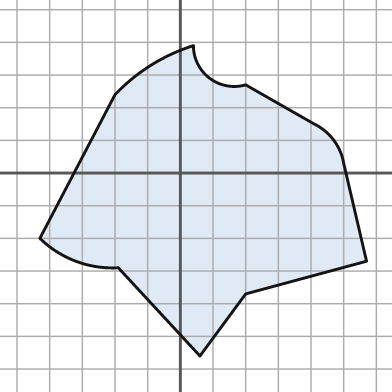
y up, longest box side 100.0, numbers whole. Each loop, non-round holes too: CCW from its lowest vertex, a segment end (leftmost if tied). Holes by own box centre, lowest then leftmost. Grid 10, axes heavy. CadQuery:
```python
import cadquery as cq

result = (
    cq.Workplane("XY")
    .moveTo(6.0, -56.0)
    .lineTo(20.0, -37.0)
    .lineTo(57.0, -27.0)
    .lineTo(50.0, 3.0)
    .threePointArc((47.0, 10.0), (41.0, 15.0))
    .lineTo(20.0, 27.0)
    .threePointArc((9.0, 29.0), (4.0, 39.0))
    .threePointArc((-9.0, 33.0), (-20.0, 24.0))
    .lineTo(-43.0, -20.0)
    .threePointArc((-32.0, -27.0), (-19.0, -29.0))
    .close()
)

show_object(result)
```